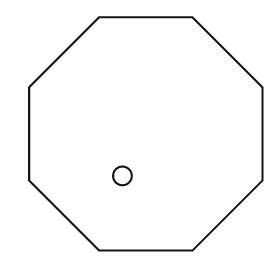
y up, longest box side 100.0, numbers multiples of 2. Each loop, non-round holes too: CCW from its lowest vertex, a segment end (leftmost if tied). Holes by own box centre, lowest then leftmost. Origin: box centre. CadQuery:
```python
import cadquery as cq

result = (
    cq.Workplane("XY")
    .moveTo(-20.0, -50.0)
    .lineTo(20.0, -50.0)
    .lineTo(50.0, -20.0)
    .lineTo(50.0, 20.0)
    .lineTo(20.0, 50.0)
    .lineTo(-20.0, 50.0)
    .lineTo(-50.0, 20.0)
    .lineTo(-50.0, -20.0)
    .close()
    .moveTo(-10.0, -18.0)
    .circle(4.0)
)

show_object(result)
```